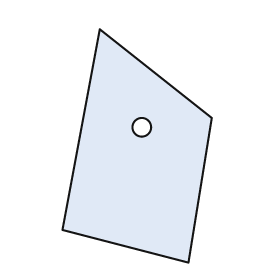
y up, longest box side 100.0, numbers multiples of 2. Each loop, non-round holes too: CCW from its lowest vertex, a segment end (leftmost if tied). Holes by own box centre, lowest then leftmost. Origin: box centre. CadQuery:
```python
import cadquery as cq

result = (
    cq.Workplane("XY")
    .moveTo(22.0, -50.0)
    .lineTo(32.0, 12.0)
    .lineTo(-16.0, 50.0)
    .lineTo(-32.0, -36.0)
    .close()
    .moveTo(2.0, 8.0)
    .circle(4.0)
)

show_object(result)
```